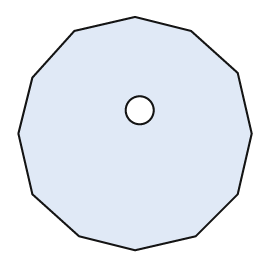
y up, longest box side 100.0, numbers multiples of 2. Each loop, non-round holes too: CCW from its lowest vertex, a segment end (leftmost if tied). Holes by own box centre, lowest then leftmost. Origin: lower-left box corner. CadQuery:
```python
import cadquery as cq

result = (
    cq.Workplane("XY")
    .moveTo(50.0, 0.0)
    .lineTo(76.0, 6.0)
    .lineTo(94.0, 24.0)
    .lineTo(100.0, 50.0)
    .lineTo(94.0, 76.0)
    .lineTo(74.0, 94.0)
    .lineTo(50.0, 100.0)
    .lineTo(24.0, 94.0)
    .lineTo(6.0, 74.0)
    .lineTo(0.0, 50.0)
    .lineTo(6.0, 24.0)
    .lineTo(26.0, 6.0)
    .close()
    .moveTo(52.0, 60.0)
    .circle(6.0)
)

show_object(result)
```